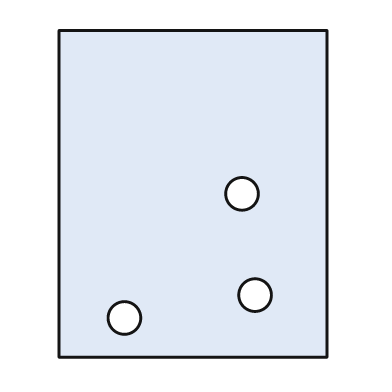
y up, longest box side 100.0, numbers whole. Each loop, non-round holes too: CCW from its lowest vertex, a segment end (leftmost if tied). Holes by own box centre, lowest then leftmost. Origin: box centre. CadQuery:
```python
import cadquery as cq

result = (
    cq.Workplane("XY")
    .moveTo(-41.0, -50.0)
    .lineTo(41.0, -50.0)
    .lineTo(41.0, 50.0)
    .lineTo(-41.0, 50.0)
    .close()
    .moveTo(-21.0, -38.0)
    .circle(5.0)
    .moveTo(19.0, -31.0)
    .circle(5.0)
    .moveTo(15.0, 0.0)
    .circle(5.0)
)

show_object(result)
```